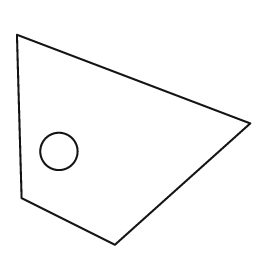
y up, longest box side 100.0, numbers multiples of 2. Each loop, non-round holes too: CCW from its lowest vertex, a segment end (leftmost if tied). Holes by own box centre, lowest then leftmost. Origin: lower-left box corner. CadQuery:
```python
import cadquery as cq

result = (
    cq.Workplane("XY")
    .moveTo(42.0, 0.0)
    .lineTo(100.0, 52.0)
    .lineTo(0.0, 90.0)
    .lineTo(2.0, 20.0)
    .close()
    .moveTo(18.0, 40.0)
    .circle(8.0)
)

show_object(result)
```